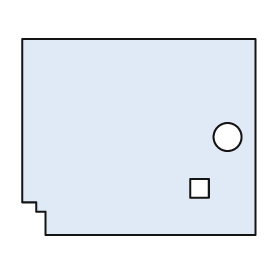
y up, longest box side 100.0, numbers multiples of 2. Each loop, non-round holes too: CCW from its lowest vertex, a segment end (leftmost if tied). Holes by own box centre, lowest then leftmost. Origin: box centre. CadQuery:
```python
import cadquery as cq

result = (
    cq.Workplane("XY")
    .moveTo(-40.0, -42.0)
    .lineTo(50.0, -42.0)
    .lineTo(50.0, 42.0)
    .lineTo(-50.0, 42.0)
    .lineTo(-50.0, -28.0)
    .lineTo(-44.0, -28.0)
    .lineTo(-44.0, -32.0)
    .lineTo(-40.0, -32.0)
    .close()
    .moveTo(22.0, -26.0)
    .lineTo(30.0, -26.0)
    .lineTo(30.0, -18.0)
    .lineTo(22.0, -18.0)
    .close()
    .moveTo(38.0, 0.0)
    .circle(6.0)
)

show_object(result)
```